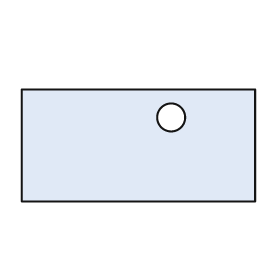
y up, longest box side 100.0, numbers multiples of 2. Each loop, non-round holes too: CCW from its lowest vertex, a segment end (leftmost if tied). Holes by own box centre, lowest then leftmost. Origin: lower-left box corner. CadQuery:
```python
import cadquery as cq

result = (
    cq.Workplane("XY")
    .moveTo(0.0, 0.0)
    .lineTo(100.0, 0.0)
    .lineTo(100.0, 48.0)
    .lineTo(0.0, 48.0)
    .close()
    .moveTo(64.0, 36.0)
    .circle(6.0)
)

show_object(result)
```